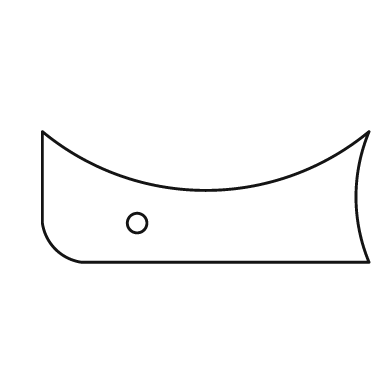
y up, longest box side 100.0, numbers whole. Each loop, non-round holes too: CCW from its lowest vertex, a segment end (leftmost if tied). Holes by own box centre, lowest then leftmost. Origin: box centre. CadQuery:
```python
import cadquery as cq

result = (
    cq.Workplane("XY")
    .moveTo(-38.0, -20.0)
    .lineTo(50.0, -20.0)
    .threePointArc((46.0, 0.0), (50.0, 20.0))
    .threePointArc((0.0, 2.0), (-50.0, 20.0))
    .lineTo(-50.0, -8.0)
    .threePointArc((-46.0, -16.0), (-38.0, -20.0))
    .close()
    .moveTo(-21.0, -8.0)
    .circle(3.0)
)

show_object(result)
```